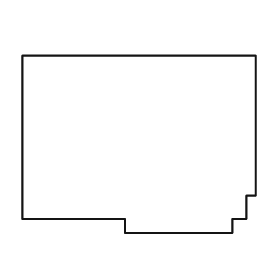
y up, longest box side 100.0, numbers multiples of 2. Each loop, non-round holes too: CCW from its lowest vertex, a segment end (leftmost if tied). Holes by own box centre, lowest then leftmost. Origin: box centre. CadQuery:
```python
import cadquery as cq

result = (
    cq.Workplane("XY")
    .moveTo(-6.0, -38.0)
    .lineTo(40.0, -38.0)
    .lineTo(40.0, -32.0)
    .lineTo(46.0, -32.0)
    .lineTo(46.0, -22.0)
    .lineTo(50.0, -22.0)
    .lineTo(50.0, 38.0)
    .lineTo(-50.0, 38.0)
    .lineTo(-50.0, -32.0)
    .lineTo(-6.0, -32.0)
    .close()
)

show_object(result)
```